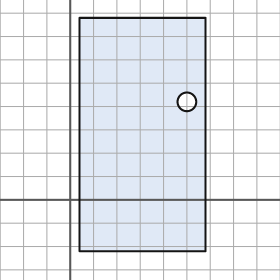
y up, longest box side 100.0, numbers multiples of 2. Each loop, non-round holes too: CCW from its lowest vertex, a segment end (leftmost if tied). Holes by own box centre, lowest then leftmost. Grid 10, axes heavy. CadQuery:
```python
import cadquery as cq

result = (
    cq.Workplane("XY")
    .moveTo(4.0, -22.0)
    .lineTo(58.0, -22.0)
    .lineTo(58.0, 78.0)
    .lineTo(4.0, 78.0)
    .close()
    .moveTo(50.0, 42.0)
    .circle(4.0)
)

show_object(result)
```